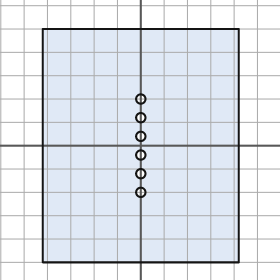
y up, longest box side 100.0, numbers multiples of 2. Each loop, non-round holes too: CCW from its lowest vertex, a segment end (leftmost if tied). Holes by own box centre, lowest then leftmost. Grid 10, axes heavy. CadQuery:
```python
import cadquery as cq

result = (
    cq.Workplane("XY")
    .moveTo(-42.0, -50.0)
    .lineTo(42.0, -50.0)
    .lineTo(42.0, 50.0)
    .lineTo(-42.0, 50.0)
    .close()
    .moveTo(0.0, -20.0)
    .circle(2.0)
    .moveTo(0.0, -12.0)
    .circle(2.0)
    .moveTo(0.0, -4.0)
    .circle(2.0)
    .moveTo(0.0, 4.0)
    .circle(2.0)
    .moveTo(0.0, 12.0)
    .circle(2.0)
    .moveTo(0.0, 20.0)
    .circle(2.0)
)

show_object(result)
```